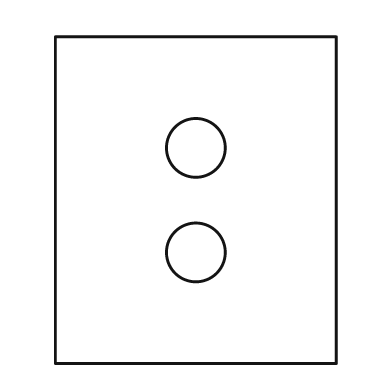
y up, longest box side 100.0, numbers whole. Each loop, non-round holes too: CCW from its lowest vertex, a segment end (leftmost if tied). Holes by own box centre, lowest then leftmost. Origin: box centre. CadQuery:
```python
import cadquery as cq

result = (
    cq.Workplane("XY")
    .moveTo(-43.0, -50.0)
    .lineTo(43.0, -50.0)
    .lineTo(43.0, 50.0)
    .lineTo(-43.0, 50.0)
    .close()
    .moveTo(0.0, -16.0)
    .circle(9.0)
    .moveTo(0.0, 16.0)
    .circle(9.0)
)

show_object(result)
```